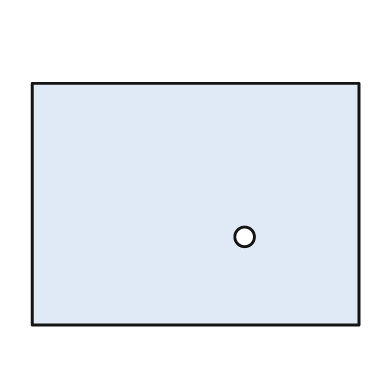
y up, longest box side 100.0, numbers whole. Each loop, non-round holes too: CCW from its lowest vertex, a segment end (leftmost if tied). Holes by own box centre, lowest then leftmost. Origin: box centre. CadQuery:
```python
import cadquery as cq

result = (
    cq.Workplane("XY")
    .moveTo(-50.0, -37.0)
    .lineTo(50.0, -37.0)
    .lineTo(50.0, 37.0)
    .lineTo(-50.0, 37.0)
    .close()
    .moveTo(15.0, -10.0)
    .circle(3.0)
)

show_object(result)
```